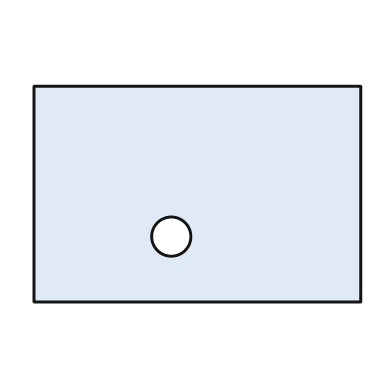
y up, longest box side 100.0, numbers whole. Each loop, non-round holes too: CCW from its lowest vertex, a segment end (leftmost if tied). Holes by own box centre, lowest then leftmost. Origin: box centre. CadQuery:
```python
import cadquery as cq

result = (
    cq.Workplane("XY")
    .moveTo(-50.0, -33.0)
    .lineTo(50.0, -33.0)
    .lineTo(50.0, 33.0)
    .lineTo(-50.0, 33.0)
    .close()
    .moveTo(-8.0, -13.0)
    .circle(6.0)
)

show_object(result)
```